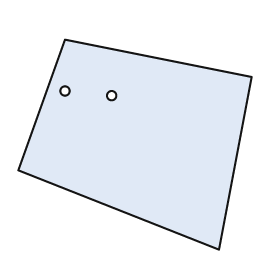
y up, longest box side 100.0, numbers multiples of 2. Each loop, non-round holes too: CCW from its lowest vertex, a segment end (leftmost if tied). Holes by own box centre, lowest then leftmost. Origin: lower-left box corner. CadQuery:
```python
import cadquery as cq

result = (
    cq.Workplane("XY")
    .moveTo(86.0, 0.0)
    .lineTo(100.0, 74.0)
    .lineTo(20.0, 90.0)
    .lineTo(0.0, 34.0)
    .close()
    .moveTo(40.0, 66.0)
    .circle(2.0)
    .moveTo(20.0, 68.0)
    .circle(2.0)
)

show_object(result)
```